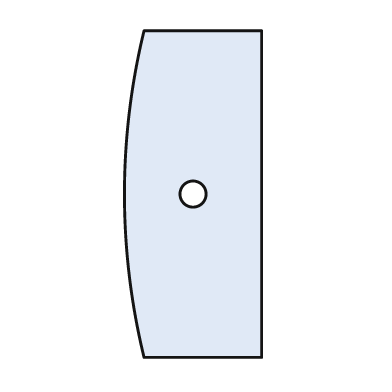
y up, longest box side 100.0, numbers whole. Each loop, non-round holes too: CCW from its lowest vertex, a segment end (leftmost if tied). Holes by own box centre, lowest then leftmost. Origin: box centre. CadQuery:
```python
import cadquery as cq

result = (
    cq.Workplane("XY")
    .moveTo(-15.0, -50.0)
    .lineTo(21.0, -50.0)
    .lineTo(21.0, 50.0)
    .lineTo(-15.0, 50.0)
    .threePointArc((-21.0, 0.0), (-15.0, -50.0))
    .close()
    .moveTo(0.0, 0.0)
    .circle(4.0)
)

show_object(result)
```